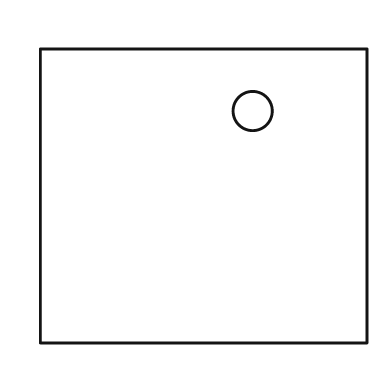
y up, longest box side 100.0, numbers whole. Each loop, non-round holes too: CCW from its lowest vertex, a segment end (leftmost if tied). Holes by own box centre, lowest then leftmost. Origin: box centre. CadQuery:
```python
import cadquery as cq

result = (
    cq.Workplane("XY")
    .moveTo(-50.0, -45.0)
    .lineTo(50.0, -45.0)
    .lineTo(50.0, 45.0)
    .lineTo(-50.0, 45.0)
    .close()
    .moveTo(15.0, 26.0)
    .circle(6.0)
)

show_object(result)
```